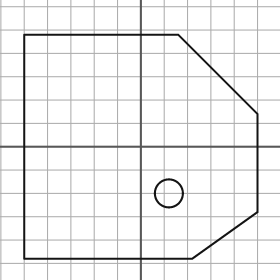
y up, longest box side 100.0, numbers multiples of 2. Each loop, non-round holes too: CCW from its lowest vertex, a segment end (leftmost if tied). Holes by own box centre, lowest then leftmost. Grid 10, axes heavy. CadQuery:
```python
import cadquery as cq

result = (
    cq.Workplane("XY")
    .moveTo(-50.0, -48.0)
    .lineTo(22.0, -48.0)
    .lineTo(50.0, -28.0)
    .lineTo(50.0, 14.0)
    .lineTo(16.0, 48.0)
    .lineTo(-50.0, 48.0)
    .close()
    .moveTo(12.0, -20.0)
    .circle(6.0)
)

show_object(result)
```